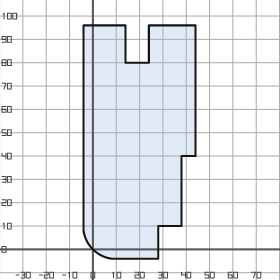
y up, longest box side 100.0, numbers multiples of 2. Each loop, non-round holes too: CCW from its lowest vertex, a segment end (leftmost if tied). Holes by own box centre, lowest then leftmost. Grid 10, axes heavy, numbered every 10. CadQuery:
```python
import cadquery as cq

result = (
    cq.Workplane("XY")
    .moveTo(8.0, -4.0)
    .lineTo(28.0, -4.0)
    .lineTo(28.0, 10.0)
    .lineTo(38.0, 10.0)
    .lineTo(38.0, 40.0)
    .lineTo(44.0, 40.0)
    .lineTo(44.0, 96.0)
    .lineTo(24.0, 96.0)
    .lineTo(24.0, 80.0)
    .lineTo(14.0, 80.0)
    .lineTo(14.0, 96.0)
    .lineTo(-4.0, 96.0)
    .lineTo(-4.0, 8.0)
    .threePointArc((0.0, 0.0), (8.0, -4.0))
    .close()
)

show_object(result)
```